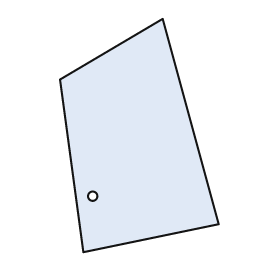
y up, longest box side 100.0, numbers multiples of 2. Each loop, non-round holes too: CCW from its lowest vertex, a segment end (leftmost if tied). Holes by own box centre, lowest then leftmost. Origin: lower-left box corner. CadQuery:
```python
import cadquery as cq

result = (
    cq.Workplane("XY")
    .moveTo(10.0, 0.0)
    .lineTo(68.0, 12.0)
    .lineTo(44.0, 100.0)
    .lineTo(0.0, 74.0)
    .close()
    .moveTo(14.0, 24.0)
    .circle(2.0)
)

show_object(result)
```